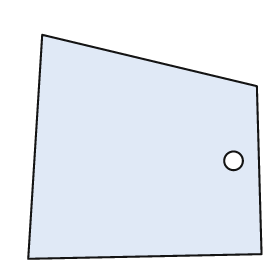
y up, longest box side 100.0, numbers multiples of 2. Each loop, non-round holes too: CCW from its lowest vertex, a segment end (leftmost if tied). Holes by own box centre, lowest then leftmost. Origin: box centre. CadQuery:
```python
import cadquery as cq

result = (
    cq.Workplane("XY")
    .moveTo(-50.0, -48.0)
    .lineTo(50.0, -46.0)
    .lineTo(48.0, 26.0)
    .lineTo(-44.0, 48.0)
    .close()
    .moveTo(38.0, -6.0)
    .circle(4.0)
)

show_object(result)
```